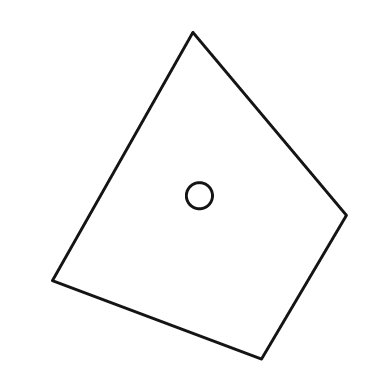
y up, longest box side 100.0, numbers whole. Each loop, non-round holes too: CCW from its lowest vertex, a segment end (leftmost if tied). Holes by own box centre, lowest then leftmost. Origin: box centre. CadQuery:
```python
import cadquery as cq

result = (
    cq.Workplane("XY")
    .moveTo(19.0, -50.0)
    .lineTo(45.0, -6.0)
    .lineTo(-2.0, 50.0)
    .lineTo(-45.0, -26.0)
    .close()
    .moveTo(0.0, 0.0)
    .circle(4.0)
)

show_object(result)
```